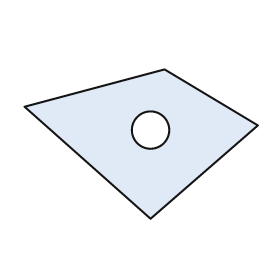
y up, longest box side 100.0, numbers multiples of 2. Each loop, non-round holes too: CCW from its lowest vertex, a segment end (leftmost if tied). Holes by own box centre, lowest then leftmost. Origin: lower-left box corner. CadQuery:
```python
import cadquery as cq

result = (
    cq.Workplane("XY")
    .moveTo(54.0, 0.0)
    .lineTo(100.0, 40.0)
    .lineTo(60.0, 64.0)
    .lineTo(0.0, 48.0)
    .close()
    .moveTo(54.0, 38.0)
    .circle(8.0)
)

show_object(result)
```